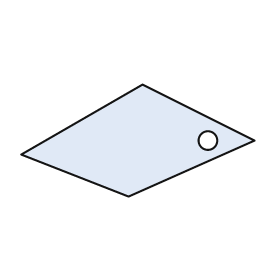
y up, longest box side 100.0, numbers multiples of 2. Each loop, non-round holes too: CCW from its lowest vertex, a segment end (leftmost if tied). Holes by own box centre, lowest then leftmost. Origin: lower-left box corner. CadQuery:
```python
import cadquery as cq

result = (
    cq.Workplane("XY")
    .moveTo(46.0, 0.0)
    .lineTo(100.0, 24.0)
    .lineTo(52.0, 48.0)
    .lineTo(0.0, 18.0)
    .close()
    .moveTo(80.0, 24.0)
    .circle(4.0)
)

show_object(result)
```